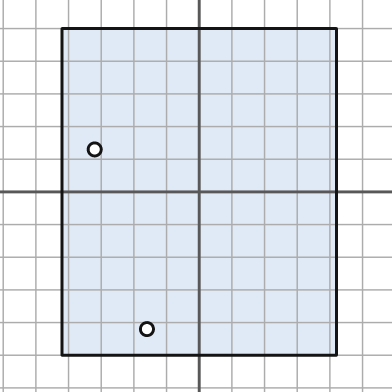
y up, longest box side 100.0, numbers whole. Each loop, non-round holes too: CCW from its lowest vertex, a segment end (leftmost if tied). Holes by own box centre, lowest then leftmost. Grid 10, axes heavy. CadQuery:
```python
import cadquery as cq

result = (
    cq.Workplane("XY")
    .moveTo(-42.0, -50.0)
    .lineTo(42.0, -50.0)
    .lineTo(42.0, 50.0)
    .lineTo(-42.0, 50.0)
    .close()
    .moveTo(-16.0, -42.0)
    .circle(2.0)
    .moveTo(-32.0, 13.0)
    .circle(2.0)
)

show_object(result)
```